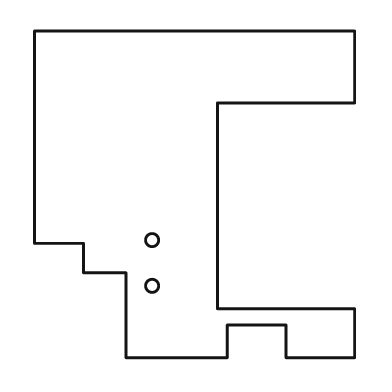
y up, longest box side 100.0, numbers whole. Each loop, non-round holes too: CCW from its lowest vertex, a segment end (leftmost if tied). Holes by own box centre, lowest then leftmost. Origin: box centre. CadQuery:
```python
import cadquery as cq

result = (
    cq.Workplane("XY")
    .moveTo(-21.0, -50.0)
    .lineTo(10.0, -50.0)
    .lineTo(10.0, -40.0)
    .lineTo(28.0, -40.0)
    .lineTo(28.0, -50.0)
    .lineTo(49.0, -50.0)
    .lineTo(49.0, -35.0)
    .lineTo(7.0, -35.0)
    .lineTo(7.0, 28.0)
    .lineTo(49.0, 28.0)
    .lineTo(49.0, 50.0)
    .lineTo(-49.0, 50.0)
    .lineTo(-49.0, -15.0)
    .lineTo(-34.0, -15.0)
    .lineTo(-34.0, -24.0)
    .lineTo(-21.0, -24.0)
    .close()
    .moveTo(-13.0, -28.0)
    .circle(2.0)
    .moveTo(-13.0, -14.0)
    .circle(2.0)
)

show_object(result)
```